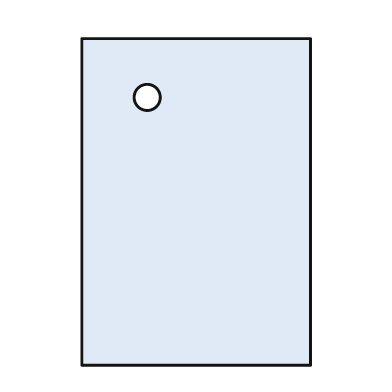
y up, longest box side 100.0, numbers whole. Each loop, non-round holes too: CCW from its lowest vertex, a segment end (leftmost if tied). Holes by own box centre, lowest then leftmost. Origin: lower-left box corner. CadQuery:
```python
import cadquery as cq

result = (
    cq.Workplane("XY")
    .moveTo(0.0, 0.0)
    .lineTo(70.0, 0.0)
    .lineTo(70.0, 100.0)
    .lineTo(0.0, 100.0)
    .close()
    .moveTo(20.0, 82.0)
    .circle(4.0)
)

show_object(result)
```